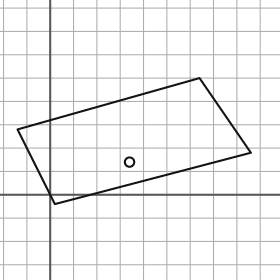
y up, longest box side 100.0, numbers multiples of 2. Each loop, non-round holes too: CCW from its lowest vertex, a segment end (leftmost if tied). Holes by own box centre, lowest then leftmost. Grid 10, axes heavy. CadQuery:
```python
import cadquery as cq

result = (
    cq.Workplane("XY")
    .moveTo(2.0, -4.0)
    .lineTo(86.0, 18.0)
    .lineTo(64.0, 50.0)
    .lineTo(-14.0, 28.0)
    .close()
    .moveTo(34.0, 14.0)
    .circle(2.0)
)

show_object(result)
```